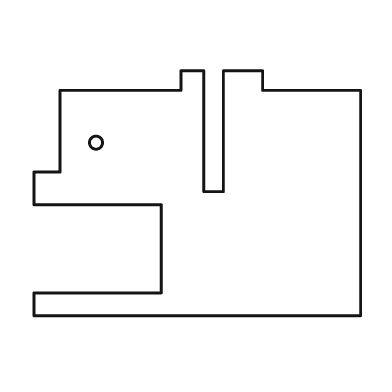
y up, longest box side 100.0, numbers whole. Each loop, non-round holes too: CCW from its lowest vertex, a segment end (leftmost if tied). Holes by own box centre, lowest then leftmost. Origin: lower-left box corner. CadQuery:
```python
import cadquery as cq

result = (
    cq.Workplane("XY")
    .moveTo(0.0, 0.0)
    .lineTo(100.0, 0.0)
    .lineTo(100.0, 69.0)
    .lineTo(70.0, 69.0)
    .lineTo(70.0, 75.0)
    .lineTo(58.0, 75.0)
    .lineTo(58.0, 38.0)
    .lineTo(52.0, 38.0)
    .lineTo(52.0, 75.0)
    .lineTo(45.0, 75.0)
    .lineTo(45.0, 69.0)
    .lineTo(8.0, 69.0)
    .lineTo(8.0, 44.0)
    .lineTo(0.0, 44.0)
    .lineTo(0.0, 34.0)
    .lineTo(39.0, 34.0)
    .lineTo(39.0, 7.0)
    .lineTo(0.0, 7.0)
    .close()
    .moveTo(19.0, 53.0)
    .circle(2.0)
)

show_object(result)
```